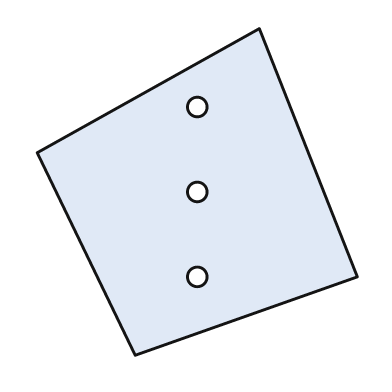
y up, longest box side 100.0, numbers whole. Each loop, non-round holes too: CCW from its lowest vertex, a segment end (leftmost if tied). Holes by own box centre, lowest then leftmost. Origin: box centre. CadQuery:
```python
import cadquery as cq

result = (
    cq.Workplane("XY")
    .moveTo(-19.0, -50.0)
    .lineTo(49.0, -26.0)
    .lineTo(19.0, 50.0)
    .lineTo(-49.0, 12.0)
    .close()
    .moveTo(0.0, -26.0)
    .circle(3.0)
    .moveTo(0.0, 0.0)
    .circle(3.0)
    .moveTo(0.0, 26.0)
    .circle(3.0)
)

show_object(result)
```